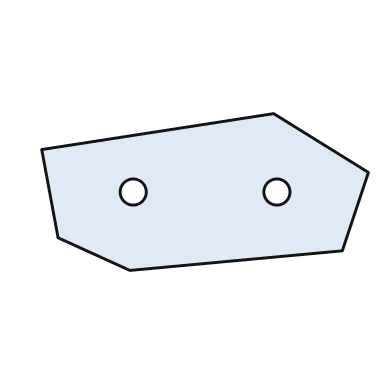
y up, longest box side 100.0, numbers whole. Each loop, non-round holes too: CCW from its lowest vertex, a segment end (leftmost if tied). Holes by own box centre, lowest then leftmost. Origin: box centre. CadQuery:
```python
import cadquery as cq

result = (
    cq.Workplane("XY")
    .moveTo(-23.0, -24.0)
    .lineTo(42.0, -18.0)
    .lineTo(50.0, 6.0)
    .lineTo(21.0, 24.0)
    .lineTo(-50.0, 13.0)
    .lineTo(-45.0, -14.0)
    .close()
    .moveTo(-22.0, 0.0)
    .circle(4.0)
    .moveTo(22.0, 0.0)
    .circle(4.0)
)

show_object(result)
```